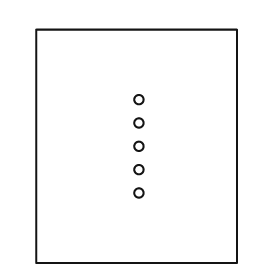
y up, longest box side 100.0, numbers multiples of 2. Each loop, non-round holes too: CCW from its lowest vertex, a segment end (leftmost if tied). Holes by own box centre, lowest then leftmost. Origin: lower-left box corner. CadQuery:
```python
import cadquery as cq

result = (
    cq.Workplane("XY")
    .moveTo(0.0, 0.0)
    .lineTo(86.0, 0.0)
    .lineTo(86.0, 100.0)
    .lineTo(0.0, 100.0)
    .close()
    .moveTo(44.0, 30.0)
    .circle(2.0)
    .moveTo(44.0, 40.0)
    .circle(2.0)
    .moveTo(44.0, 50.0)
    .circle(2.0)
    .moveTo(44.0, 60.0)
    .circle(2.0)
    .moveTo(44.0, 70.0)
    .circle(2.0)
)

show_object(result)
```